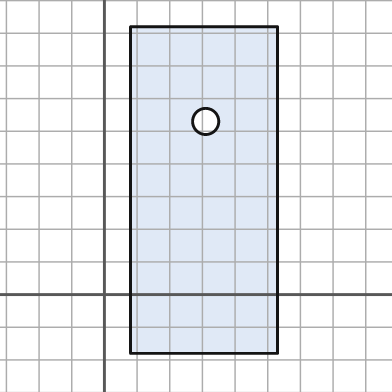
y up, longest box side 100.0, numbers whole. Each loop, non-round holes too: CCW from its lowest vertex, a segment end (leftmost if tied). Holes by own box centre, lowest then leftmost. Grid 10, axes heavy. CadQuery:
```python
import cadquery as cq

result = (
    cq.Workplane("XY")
    .moveTo(8.0, -18.0)
    .lineTo(53.0, -18.0)
    .lineTo(53.0, 82.0)
    .lineTo(8.0, 82.0)
    .close()
    .moveTo(31.0, 53.0)
    .circle(4.0)
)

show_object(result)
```